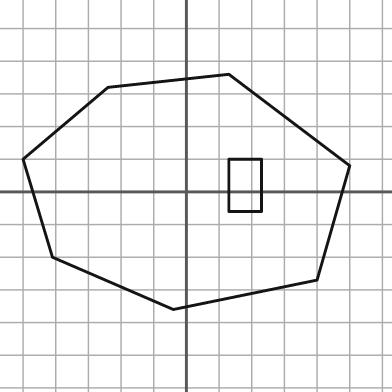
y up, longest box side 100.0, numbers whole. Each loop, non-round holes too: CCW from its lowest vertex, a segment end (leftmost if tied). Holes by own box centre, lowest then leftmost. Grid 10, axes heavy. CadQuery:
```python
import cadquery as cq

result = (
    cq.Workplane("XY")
    .moveTo(-4.0, -36.0)
    .lineTo(40.0, -27.0)
    .lineTo(50.0, 8.0)
    .lineTo(13.0, 36.0)
    .lineTo(-24.0, 32.0)
    .lineTo(-50.0, 10.0)
    .lineTo(-41.0, -20.0)
    .close()
    .moveTo(13.0, -6.0)
    .lineTo(23.0, -6.0)
    .lineTo(23.0, 10.0)
    .lineTo(13.0, 10.0)
    .close()
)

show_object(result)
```